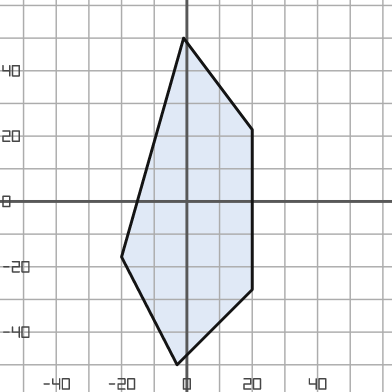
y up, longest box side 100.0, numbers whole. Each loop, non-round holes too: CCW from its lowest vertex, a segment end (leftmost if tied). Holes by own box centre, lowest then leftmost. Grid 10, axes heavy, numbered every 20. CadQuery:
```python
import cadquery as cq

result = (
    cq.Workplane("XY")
    .moveTo(-3.0, -50.0)
    .lineTo(20.0, -27.0)
    .lineTo(20.0, 22.0)
    .lineTo(-1.0, 50.0)
    .lineTo(-20.0, -17.0)
    .close()
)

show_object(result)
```